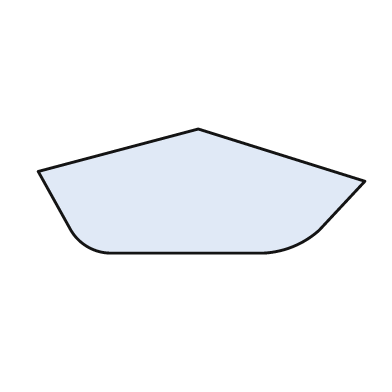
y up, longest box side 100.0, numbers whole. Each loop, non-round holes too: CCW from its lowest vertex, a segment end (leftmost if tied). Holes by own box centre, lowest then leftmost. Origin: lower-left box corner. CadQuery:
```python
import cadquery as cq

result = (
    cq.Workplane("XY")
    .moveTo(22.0, 0.0)
    .lineTo(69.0, 0.0)
    .threePointArc((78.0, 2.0), (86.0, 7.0))
    .lineTo(100.0, 22.0)
    .lineTo(49.0, 38.0)
    .lineTo(0.0, 25.0)
    .lineTo(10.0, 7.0)
    .threePointArc((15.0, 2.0), (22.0, 0.0))
    .close()
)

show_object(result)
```